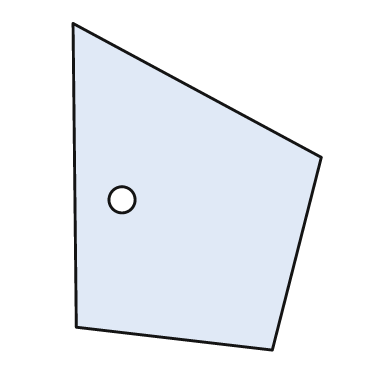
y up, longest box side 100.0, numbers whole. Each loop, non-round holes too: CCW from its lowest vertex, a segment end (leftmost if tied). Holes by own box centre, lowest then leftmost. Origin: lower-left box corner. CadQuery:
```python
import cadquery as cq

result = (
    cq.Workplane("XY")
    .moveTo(61.0, 0.0)
    .lineTo(76.0, 59.0)
    .lineTo(0.0, 100.0)
    .lineTo(1.0, 7.0)
    .close()
    .moveTo(15.0, 46.0)
    .circle(4.0)
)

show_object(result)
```